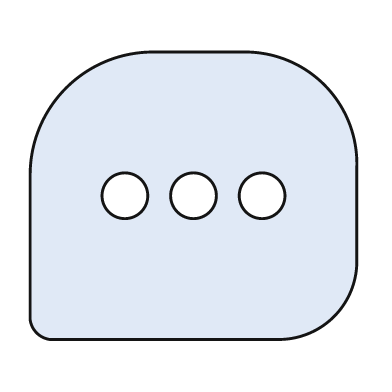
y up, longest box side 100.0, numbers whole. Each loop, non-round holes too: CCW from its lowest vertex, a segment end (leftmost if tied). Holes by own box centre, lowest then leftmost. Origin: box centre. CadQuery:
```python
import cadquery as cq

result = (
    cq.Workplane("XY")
    .moveTo(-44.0, -44.0)
    .lineTo(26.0, -44.0)
    .threePointArc((43.0, -37.0), (50.0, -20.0))
    .lineTo(50.0, 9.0)
    .threePointArc((40.0, 34.0), (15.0, 44.0))
    .lineTo(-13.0, 44.0)
    .threePointArc((-39.0, 33.0), (-50.0, 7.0))
    .lineTo(-50.0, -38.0)
    .threePointArc((-48.0, -42.0), (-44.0, -44.0))
    .close()
    .moveTo(-21.0, 0.0)
    .circle(7.0)
    .moveTo(0.0, 0.0)
    .circle(7.0)
    .moveTo(21.0, 0.0)
    .circle(7.0)
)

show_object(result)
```